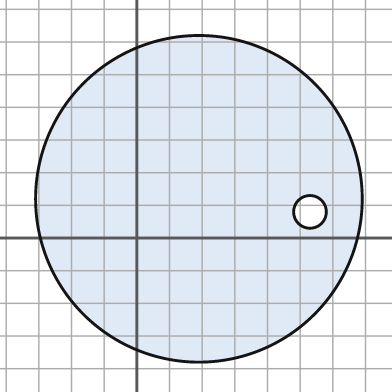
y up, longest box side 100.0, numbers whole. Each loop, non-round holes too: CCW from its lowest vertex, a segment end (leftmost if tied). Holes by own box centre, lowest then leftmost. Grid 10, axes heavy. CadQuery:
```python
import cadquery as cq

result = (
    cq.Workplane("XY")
    .moveTo(19.0, 12.0)
    .circle(50.0)
    .moveTo(53.0, 8.0)
    .circle(5.0)
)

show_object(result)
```